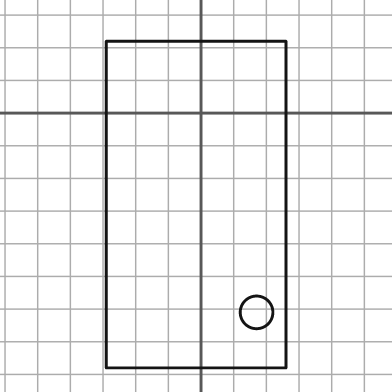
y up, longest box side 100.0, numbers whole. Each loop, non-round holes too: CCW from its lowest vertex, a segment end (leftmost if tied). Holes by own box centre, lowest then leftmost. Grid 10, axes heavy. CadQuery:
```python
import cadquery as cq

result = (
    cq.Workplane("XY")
    .moveTo(-29.0, -78.0)
    .lineTo(26.0, -78.0)
    .lineTo(26.0, 22.0)
    .lineTo(-29.0, 22.0)
    .close()
    .moveTo(17.0, -61.0)
    .circle(5.0)
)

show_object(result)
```